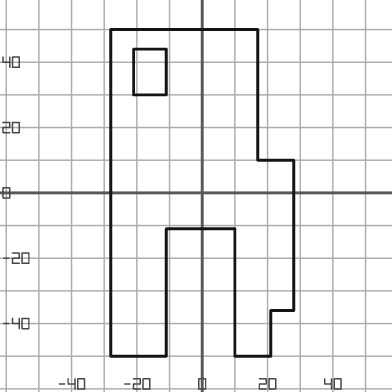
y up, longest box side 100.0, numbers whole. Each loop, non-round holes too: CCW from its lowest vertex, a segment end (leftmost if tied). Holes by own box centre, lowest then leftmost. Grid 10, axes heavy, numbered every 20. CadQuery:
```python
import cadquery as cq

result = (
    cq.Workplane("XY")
    .moveTo(-28.0, -50.0)
    .lineTo(-11.0, -50.0)
    .lineTo(-11.0, -11.0)
    .lineTo(10.0, -11.0)
    .lineTo(10.0, -50.0)
    .lineTo(21.0, -50.0)
    .lineTo(21.0, -36.0)
    .lineTo(28.0, -36.0)
    .lineTo(28.0, 10.0)
    .lineTo(17.0, 10.0)
    .lineTo(17.0, 50.0)
    .lineTo(-28.0, 50.0)
    .close()
    .moveTo(-21.0, 30.0)
    .lineTo(-11.0, 30.0)
    .lineTo(-11.0, 44.0)
    .lineTo(-21.0, 44.0)
    .close()
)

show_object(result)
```